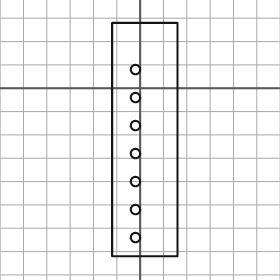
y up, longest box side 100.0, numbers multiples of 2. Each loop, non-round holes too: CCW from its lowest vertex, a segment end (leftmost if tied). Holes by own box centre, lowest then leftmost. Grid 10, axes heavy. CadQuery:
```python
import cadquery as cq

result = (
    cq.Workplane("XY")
    .moveTo(-12.0, -72.0)
    .lineTo(16.0, -72.0)
    .lineTo(16.0, 28.0)
    .lineTo(-12.0, 28.0)
    .close()
    .moveTo(-2.0, -64.0)
    .circle(2.0)
    .moveTo(-2.0, -52.0)
    .circle(2.0)
    .moveTo(-2.0, -40.0)
    .circle(2.0)
    .moveTo(-2.0, -28.0)
    .circle(2.0)
    .moveTo(-2.0, -16.0)
    .circle(2.0)
    .moveTo(-2.0, -4.0)
    .circle(2.0)
    .moveTo(-2.0, 8.0)
    .circle(2.0)
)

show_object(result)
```